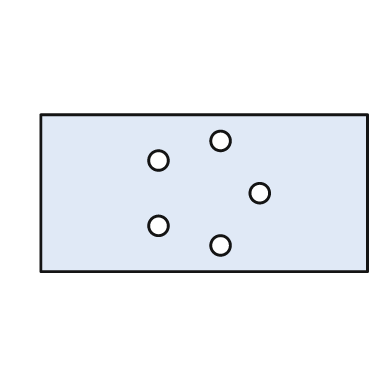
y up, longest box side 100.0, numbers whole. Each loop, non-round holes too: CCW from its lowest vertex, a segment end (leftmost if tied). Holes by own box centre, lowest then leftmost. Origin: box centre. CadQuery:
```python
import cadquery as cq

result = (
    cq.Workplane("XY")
    .moveTo(-50.0, -24.0)
    .lineTo(50.0, -24.0)
    .lineTo(50.0, 24.0)
    .lineTo(-50.0, 24.0)
    .close()
    .moveTo(5.0, -16.0)
    .circle(3.0)
    .moveTo(-14.0, -10.0)
    .circle(3.0)
    .moveTo(17.0, 0.0)
    .circle(3.0)
    .moveTo(-14.0, 10.0)
    .circle(3.0)
    .moveTo(5.0, 16.0)
    .circle(3.0)
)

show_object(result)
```